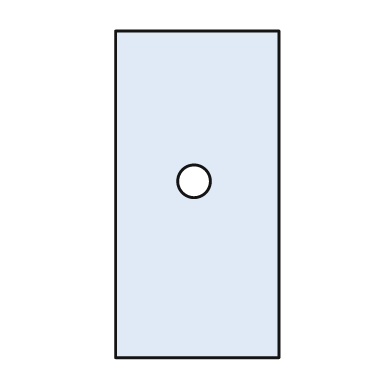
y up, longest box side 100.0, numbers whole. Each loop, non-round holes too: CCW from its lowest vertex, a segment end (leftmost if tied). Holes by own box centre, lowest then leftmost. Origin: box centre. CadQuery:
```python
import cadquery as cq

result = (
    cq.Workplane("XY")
    .moveTo(-25.0, -50.0)
    .lineTo(25.0, -50.0)
    .lineTo(25.0, 50.0)
    .lineTo(-25.0, 50.0)
    .close()
    .moveTo(-1.0, 4.0)
    .circle(5.0)
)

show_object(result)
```